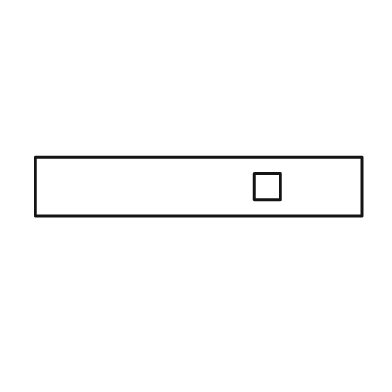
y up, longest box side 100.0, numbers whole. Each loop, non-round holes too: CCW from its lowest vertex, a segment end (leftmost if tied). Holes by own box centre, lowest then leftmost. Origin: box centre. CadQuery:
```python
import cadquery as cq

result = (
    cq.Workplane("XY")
    .moveTo(-50.0, -9.0)
    .lineTo(50.0, -9.0)
    .lineTo(50.0, 9.0)
    .lineTo(-50.0, 9.0)
    .close()
    .moveTo(17.0, -4.0)
    .lineTo(25.0, -4.0)
    .lineTo(25.0, 4.0)
    .lineTo(17.0, 4.0)
    .close()
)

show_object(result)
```